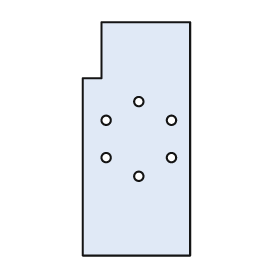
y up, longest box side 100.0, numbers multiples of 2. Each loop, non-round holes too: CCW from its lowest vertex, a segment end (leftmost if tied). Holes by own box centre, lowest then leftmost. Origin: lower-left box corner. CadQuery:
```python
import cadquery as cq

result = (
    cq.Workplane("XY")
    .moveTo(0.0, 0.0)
    .lineTo(46.0, 0.0)
    .lineTo(46.0, 100.0)
    .lineTo(8.0, 100.0)
    .lineTo(8.0, 76.0)
    .lineTo(0.0, 76.0)
    .close()
    .moveTo(24.0, 34.0)
    .circle(2.0)
    .moveTo(10.0, 42.0)
    .circle(2.0)
    .moveTo(38.0, 42.0)
    .circle(2.0)
    .moveTo(10.0, 58.0)
    .circle(2.0)
    .moveTo(38.0, 58.0)
    .circle(2.0)
    .moveTo(24.0, 66.0)
    .circle(2.0)
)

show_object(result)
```